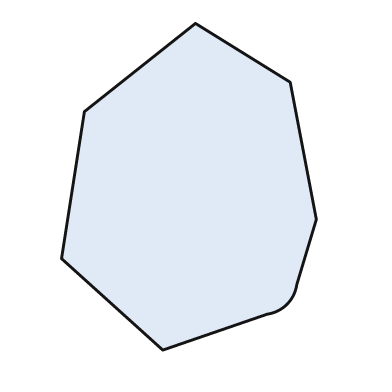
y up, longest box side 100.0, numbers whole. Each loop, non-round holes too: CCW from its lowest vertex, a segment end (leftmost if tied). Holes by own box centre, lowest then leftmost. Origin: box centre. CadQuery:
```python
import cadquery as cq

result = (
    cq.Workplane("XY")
    .moveTo(-8.0, -50.0)
    .lineTo(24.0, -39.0)
    .threePointArc((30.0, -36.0), (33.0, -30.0))
    .lineTo(39.0, -10.0)
    .lineTo(31.0, 32.0)
    .lineTo(2.0, 50.0)
    .lineTo(-32.0, 23.0)
    .lineTo(-39.0, -22.0)
    .close()
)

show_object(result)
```